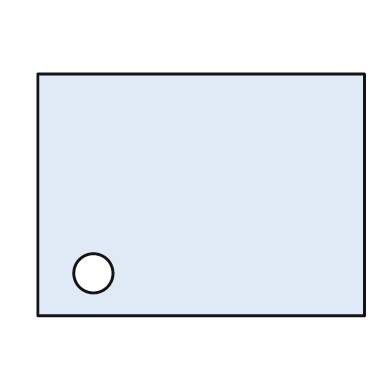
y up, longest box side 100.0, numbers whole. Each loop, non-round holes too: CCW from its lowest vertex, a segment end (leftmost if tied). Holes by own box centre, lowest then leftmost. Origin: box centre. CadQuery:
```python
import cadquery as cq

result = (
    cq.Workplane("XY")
    .moveTo(-50.0, -37.0)
    .lineTo(50.0, -37.0)
    .lineTo(50.0, 37.0)
    .lineTo(-50.0, 37.0)
    .close()
    .moveTo(-33.0, -24.0)
    .circle(6.0)
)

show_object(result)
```